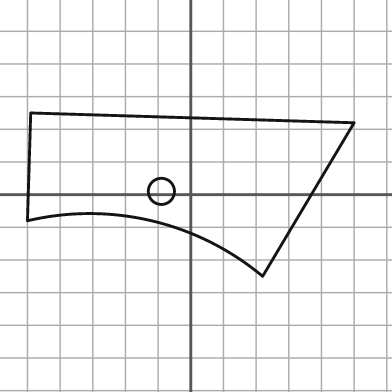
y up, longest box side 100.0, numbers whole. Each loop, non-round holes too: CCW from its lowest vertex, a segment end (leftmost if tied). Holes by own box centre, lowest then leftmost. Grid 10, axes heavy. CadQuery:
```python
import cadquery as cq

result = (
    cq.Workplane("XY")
    .moveTo(22.0, -25.0)
    .lineTo(50.0, 22.0)
    .lineTo(-49.0, 25.0)
    .lineTo(-50.0, -8.0)
    .threePointArc((-12.0, -8.0), (22.0, -25.0))
    .close()
    .moveTo(-9.0, 1.0)
    .circle(4.0)
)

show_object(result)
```